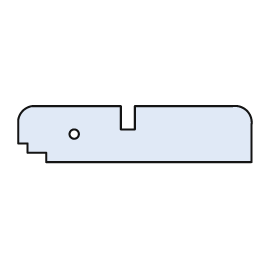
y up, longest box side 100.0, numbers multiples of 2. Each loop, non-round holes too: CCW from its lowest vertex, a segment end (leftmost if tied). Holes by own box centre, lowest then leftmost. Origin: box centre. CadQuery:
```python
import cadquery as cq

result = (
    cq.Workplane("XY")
    .moveTo(-38.0, -12.0)
    .lineTo(50.0, -12.0)
    .lineTo(50.0, 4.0)
    .threePointArc((48.0, 10.0), (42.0, 12.0))
    .lineTo(0.0, 12.0)
    .lineTo(0.0, 2.0)
    .lineTo(-6.0, 2.0)
    .lineTo(-6.0, 12.0)
    .lineTo(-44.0, 12.0)
    .threePointArc((-48.0, 10.0), (-50.0, 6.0))
    .lineTo(-50.0, -4.0)
    .lineTo(-46.0, -4.0)
    .lineTo(-46.0, -8.0)
    .lineTo(-38.0, -8.0)
    .close()
    .moveTo(-26.0, 0.0)
    .circle(2.0)
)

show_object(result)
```